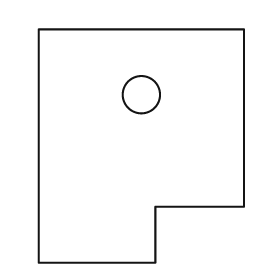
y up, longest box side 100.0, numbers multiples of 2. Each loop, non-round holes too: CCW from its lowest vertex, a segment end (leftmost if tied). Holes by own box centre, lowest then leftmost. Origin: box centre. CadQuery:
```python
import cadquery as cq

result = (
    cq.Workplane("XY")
    .moveTo(-44.0, -50.0)
    .lineTo(6.0, -50.0)
    .lineTo(6.0, -26.0)
    .lineTo(44.0, -26.0)
    .lineTo(44.0, 50.0)
    .lineTo(-44.0, 50.0)
    .close()
    .moveTo(0.0, 22.0)
    .circle(8.0)
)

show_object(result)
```